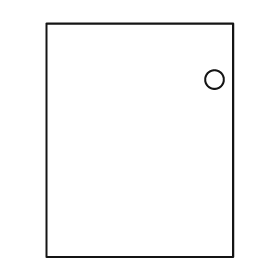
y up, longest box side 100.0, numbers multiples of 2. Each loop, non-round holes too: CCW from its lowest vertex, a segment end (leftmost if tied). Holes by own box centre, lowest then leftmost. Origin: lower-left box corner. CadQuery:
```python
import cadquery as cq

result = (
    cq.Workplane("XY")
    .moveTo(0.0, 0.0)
    .lineTo(80.0, 0.0)
    .lineTo(80.0, 100.0)
    .lineTo(0.0, 100.0)
    .close()
    .moveTo(72.0, 76.0)
    .circle(4.0)
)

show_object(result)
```